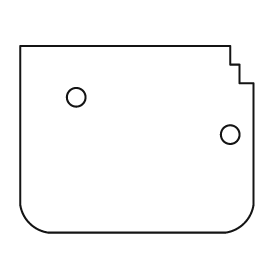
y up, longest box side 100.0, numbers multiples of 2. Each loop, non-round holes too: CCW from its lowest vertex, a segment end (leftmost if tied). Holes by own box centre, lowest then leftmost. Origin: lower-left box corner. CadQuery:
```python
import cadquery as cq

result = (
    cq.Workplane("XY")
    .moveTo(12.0, 0.0)
    .lineTo(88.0, 0.0)
    .threePointArc((96.0, 4.0), (100.0, 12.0))
    .lineTo(100.0, 64.0)
    .lineTo(94.0, 64.0)
    .lineTo(94.0, 72.0)
    .lineTo(90.0, 72.0)
    .lineTo(90.0, 80.0)
    .lineTo(0.0, 80.0)
    .lineTo(0.0, 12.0)
    .threePointArc((4.0, 4.0), (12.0, 0.0))
    .close()
    .moveTo(90.0, 42.0)
    .circle(4.0)
    .moveTo(24.0, 58.0)
    .circle(4.0)
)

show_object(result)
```